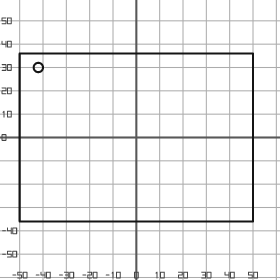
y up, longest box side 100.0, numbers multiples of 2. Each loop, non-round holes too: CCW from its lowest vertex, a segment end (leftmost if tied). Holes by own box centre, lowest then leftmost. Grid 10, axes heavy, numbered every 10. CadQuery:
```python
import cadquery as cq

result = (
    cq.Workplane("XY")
    .moveTo(-50.0, -36.0)
    .lineTo(50.0, -36.0)
    .lineTo(50.0, 36.0)
    .lineTo(-50.0, 36.0)
    .close()
    .moveTo(-42.0, 30.0)
    .circle(2.0)
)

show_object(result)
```